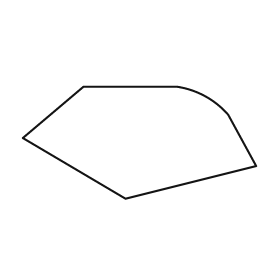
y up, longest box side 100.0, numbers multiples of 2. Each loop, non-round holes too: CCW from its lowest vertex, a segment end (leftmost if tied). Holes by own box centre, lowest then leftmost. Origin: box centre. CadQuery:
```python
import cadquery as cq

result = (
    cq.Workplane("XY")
    .moveTo(-6.0, -24.0)
    .lineTo(50.0, -10.0)
    .lineTo(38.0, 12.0)
    .threePointArc((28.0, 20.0), (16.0, 24.0))
    .lineTo(-24.0, 24.0)
    .lineTo(-50.0, 2.0)
    .close()
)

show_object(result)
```